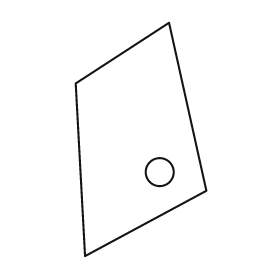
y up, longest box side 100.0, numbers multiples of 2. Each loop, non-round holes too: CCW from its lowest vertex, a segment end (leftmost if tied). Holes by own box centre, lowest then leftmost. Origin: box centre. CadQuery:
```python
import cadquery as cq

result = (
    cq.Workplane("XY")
    .moveTo(-24.0, -50.0)
    .lineTo(28.0, -22.0)
    .lineTo(12.0, 50.0)
    .lineTo(-28.0, 24.0)
    .close()
    .moveTo(8.0, -14.0)
    .circle(6.0)
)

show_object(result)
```